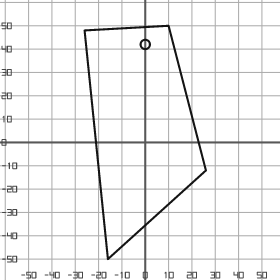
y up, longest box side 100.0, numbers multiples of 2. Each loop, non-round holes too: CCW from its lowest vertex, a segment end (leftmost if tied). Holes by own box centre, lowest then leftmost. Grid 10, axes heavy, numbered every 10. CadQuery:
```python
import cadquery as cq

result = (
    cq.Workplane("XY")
    .moveTo(-16.0, -50.0)
    .lineTo(26.0, -12.0)
    .lineTo(10.0, 50.0)
    .lineTo(-26.0, 48.0)
    .close()
    .moveTo(0.0, 42.0)
    .circle(2.0)
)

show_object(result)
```